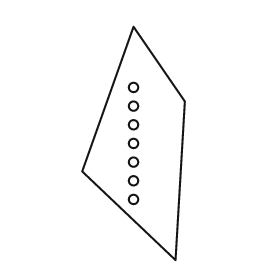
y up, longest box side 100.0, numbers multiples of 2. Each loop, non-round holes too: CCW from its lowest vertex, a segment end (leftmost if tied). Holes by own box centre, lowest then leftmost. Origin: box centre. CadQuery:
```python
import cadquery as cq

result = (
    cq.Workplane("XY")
    .moveTo(18.0, -50.0)
    .lineTo(22.0, 18.0)
    .lineTo(0.0, 50.0)
    .lineTo(-22.0, -12.0)
    .close()
    .moveTo(0.0, -24.0)
    .circle(2.0)
    .moveTo(0.0, -16.0)
    .circle(2.0)
    .moveTo(0.0, -8.0)
    .circle(2.0)
    .moveTo(0.0, 0.0)
    .circle(2.0)
    .moveTo(0.0, 8.0)
    .circle(2.0)
    .moveTo(0.0, 16.0)
    .circle(2.0)
    .moveTo(0.0, 24.0)
    .circle(2.0)
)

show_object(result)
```